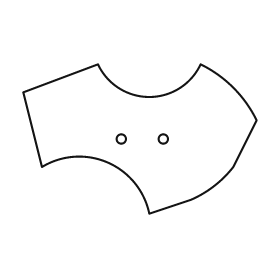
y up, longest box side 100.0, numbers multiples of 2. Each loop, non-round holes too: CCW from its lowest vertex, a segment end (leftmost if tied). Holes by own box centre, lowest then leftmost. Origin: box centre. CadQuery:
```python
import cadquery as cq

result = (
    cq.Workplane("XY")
    .moveTo(4.0, -32.0)
    .lineTo(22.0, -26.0)
    .threePointArc((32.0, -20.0), (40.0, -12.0))
    .lineTo(50.0, 8.0)
    .threePointArc((40.0, 22.0), (26.0, 32.0))
    .threePointArc((4.0, 18.0), (-18.0, 32.0))
    .lineTo(-50.0, 20.0)
    .lineTo(-42.0, -12.0)
    .threePointArc((-14.0, -10.0), (4.0, -32.0))
    .close()
    .moveTo(-8.0, 0.0)
    .circle(2.0)
    .moveTo(10.0, 0.0)
    .circle(2.0)
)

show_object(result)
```